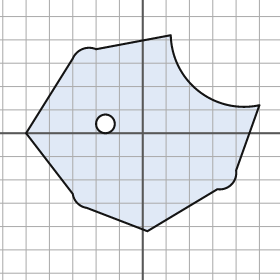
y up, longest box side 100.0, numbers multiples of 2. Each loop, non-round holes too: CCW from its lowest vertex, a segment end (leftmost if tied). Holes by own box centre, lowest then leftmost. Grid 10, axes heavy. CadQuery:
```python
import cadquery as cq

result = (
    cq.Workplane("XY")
    .moveTo(2.0, -42.0)
    .lineTo(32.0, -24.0)
    .threePointArc((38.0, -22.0), (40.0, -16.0))
    .lineTo(50.0, 12.0)
    .threePointArc((24.0, 18.0), (12.0, 42.0))
    .lineTo(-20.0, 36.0)
    .threePointArc((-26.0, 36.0), (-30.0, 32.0))
    .lineTo(-50.0, 0.0)
    .lineTo(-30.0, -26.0)
    .threePointArc((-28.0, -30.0), (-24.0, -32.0))
    .close()
    .moveTo(-16.0, 4.0)
    .circle(4.0)
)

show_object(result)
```